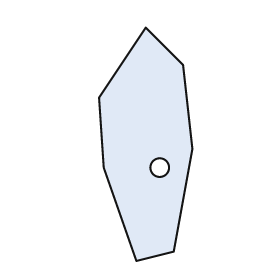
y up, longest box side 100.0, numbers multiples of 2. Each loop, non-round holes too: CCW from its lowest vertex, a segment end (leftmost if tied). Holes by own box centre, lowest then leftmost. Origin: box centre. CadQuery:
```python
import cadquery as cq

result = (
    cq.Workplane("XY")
    .moveTo(-4.0, -50.0)
    .lineTo(12.0, -46.0)
    .lineTo(20.0, -2.0)
    .lineTo(16.0, 34.0)
    .lineTo(0.0, 50.0)
    .lineTo(-20.0, 20.0)
    .lineTo(-18.0, -10.0)
    .close()
    .moveTo(6.0, -10.0)
    .circle(4.0)
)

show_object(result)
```